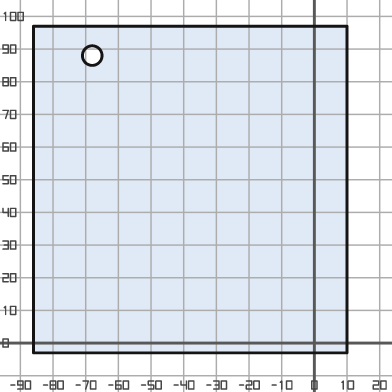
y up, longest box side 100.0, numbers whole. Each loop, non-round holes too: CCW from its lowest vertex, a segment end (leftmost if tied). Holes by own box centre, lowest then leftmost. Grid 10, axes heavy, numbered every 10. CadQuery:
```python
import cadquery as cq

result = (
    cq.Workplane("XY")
    .moveTo(-86.0, -3.0)
    .lineTo(10.0, -3.0)
    .lineTo(10.0, 97.0)
    .lineTo(-86.0, 97.0)
    .close()
    .moveTo(-68.0, 88.0)
    .circle(3.0)
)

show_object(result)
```